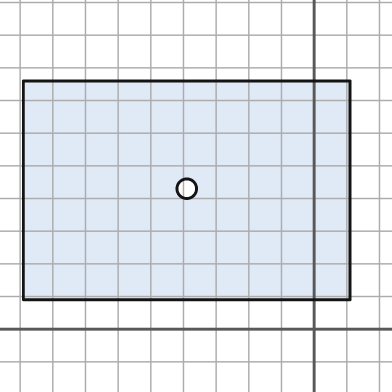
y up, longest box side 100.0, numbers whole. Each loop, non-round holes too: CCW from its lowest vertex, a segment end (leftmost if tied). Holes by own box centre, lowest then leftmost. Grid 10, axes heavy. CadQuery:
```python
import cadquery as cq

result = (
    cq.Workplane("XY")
    .moveTo(-89.0, 9.0)
    .lineTo(11.0, 9.0)
    .lineTo(11.0, 76.0)
    .lineTo(-89.0, 76.0)
    .close()
    .moveTo(-39.0, 43.0)
    .circle(3.0)
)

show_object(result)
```